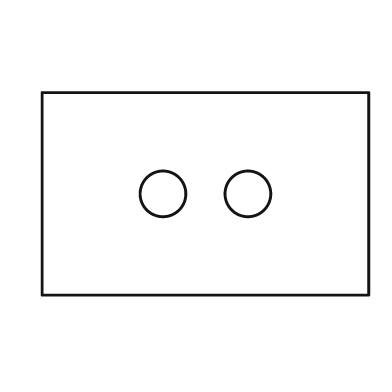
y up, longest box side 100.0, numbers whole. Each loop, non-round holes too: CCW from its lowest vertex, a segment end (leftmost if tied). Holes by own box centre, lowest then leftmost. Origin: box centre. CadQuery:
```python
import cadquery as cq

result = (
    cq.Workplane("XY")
    .moveTo(-50.0, -31.0)
    .lineTo(50.0, -31.0)
    .lineTo(50.0, 31.0)
    .lineTo(-50.0, 31.0)
    .close()
    .moveTo(-13.0, 0.0)
    .circle(7.0)
    .moveTo(13.0, 0.0)
    .circle(7.0)
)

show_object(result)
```